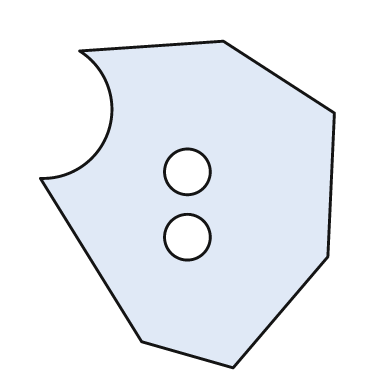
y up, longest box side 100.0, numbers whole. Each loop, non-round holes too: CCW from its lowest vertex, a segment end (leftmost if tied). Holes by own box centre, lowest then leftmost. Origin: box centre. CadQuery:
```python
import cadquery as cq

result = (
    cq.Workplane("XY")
    .moveTo(14.0, -50.0)
    .lineTo(43.0, -16.0)
    .lineTo(45.0, 28.0)
    .lineTo(11.0, 50.0)
    .lineTo(-33.0, 47.0)
    .threePointArc((-24.0, 23.0), (-45.0, 8.0))
    .lineTo(-14.0, -42.0)
    .close()
    .moveTo(0.0, -10.0)
    .circle(7.0)
    .moveTo(0.0, 10.0)
    .circle(7.0)
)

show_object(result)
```